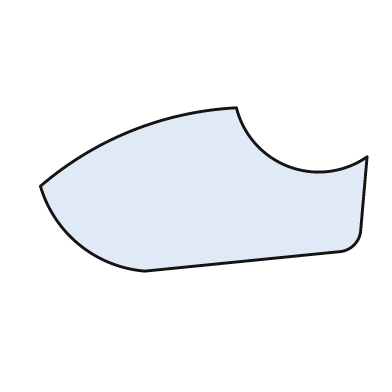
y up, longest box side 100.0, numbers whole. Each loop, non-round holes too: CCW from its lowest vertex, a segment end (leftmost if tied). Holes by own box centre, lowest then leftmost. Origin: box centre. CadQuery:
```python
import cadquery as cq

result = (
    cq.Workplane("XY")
    .moveTo(-18.0, -25.0)
    .lineTo(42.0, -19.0)
    .threePointArc((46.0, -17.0), (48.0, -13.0))
    .lineTo(50.0, 10.0)
    .threePointArc((26.0, 7.0), (10.0, 25.0))
    .threePointArc((-22.0, 18.0), (-50.0, 1.0))
    .threePointArc((-38.0, -17.0), (-18.0, -25.0))
    .close()
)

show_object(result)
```